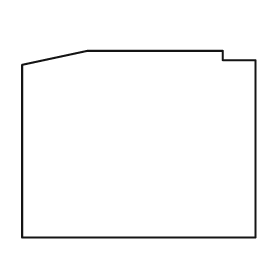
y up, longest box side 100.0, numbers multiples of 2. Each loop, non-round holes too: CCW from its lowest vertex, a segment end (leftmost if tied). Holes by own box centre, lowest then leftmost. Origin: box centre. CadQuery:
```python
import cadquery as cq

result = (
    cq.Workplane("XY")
    .moveTo(-50.0, -40.0)
    .lineTo(50.0, -40.0)
    .lineTo(50.0, 36.0)
    .lineTo(36.0, 36.0)
    .lineTo(36.0, 40.0)
    .lineTo(-22.0, 40.0)
    .lineTo(-50.0, 34.0)
    .close()
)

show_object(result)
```